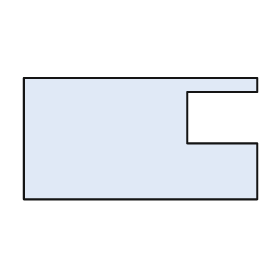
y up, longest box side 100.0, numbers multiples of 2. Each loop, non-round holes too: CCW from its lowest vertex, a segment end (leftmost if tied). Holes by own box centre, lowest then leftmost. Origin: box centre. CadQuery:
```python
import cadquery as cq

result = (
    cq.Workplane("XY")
    .moveTo(-50.0, -26.0)
    .lineTo(50.0, -26.0)
    .lineTo(50.0, -2.0)
    .lineTo(20.0, -2.0)
    .lineTo(20.0, 20.0)
    .lineTo(50.0, 20.0)
    .lineTo(50.0, 26.0)
    .lineTo(-50.0, 26.0)
    .close()
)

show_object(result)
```